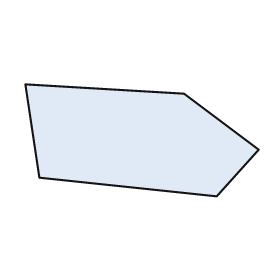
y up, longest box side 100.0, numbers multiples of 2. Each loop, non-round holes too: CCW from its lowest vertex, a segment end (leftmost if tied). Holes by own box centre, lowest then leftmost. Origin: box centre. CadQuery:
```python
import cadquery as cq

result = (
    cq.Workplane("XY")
    .moveTo(32.0, -24.0)
    .lineTo(50.0, -4.0)
    .lineTo(18.0, 20.0)
    .lineTo(-50.0, 24.0)
    .lineTo(-44.0, -16.0)
    .close()
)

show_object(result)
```